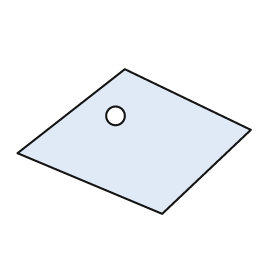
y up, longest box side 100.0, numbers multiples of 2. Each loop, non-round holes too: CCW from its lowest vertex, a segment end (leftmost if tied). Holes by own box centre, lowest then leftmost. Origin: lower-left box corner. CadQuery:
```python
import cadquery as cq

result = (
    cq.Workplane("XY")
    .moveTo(62.0, 0.0)
    .lineTo(100.0, 36.0)
    .lineTo(46.0, 62.0)
    .lineTo(0.0, 26.0)
    .close()
    .moveTo(42.0, 42.0)
    .circle(4.0)
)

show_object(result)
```